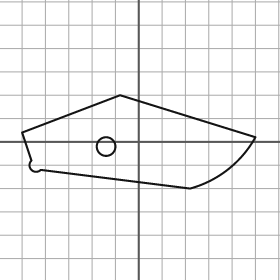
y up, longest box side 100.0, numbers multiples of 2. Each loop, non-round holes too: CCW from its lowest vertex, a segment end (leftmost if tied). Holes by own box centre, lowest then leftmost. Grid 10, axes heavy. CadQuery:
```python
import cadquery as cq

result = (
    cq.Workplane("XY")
    .moveTo(22.0, -20.0)
    .threePointArc((38.0, -12.0), (50.0, 2.0))
    .lineTo(-8.0, 20.0)
    .lineTo(-50.0, 4.0)
    .lineTo(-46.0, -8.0)
    .threePointArc((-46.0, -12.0), (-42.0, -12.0))
    .close()
    .moveTo(-14.0, -2.0)
    .circle(4.0)
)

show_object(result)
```